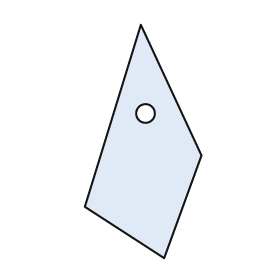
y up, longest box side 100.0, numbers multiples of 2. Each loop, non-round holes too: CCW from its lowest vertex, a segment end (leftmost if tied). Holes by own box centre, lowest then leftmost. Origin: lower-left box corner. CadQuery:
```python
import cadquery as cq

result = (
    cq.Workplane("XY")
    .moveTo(34.0, 0.0)
    .lineTo(50.0, 44.0)
    .lineTo(24.0, 100.0)
    .lineTo(0.0, 22.0)
    .close()
    .moveTo(26.0, 62.0)
    .circle(4.0)
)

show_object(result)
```